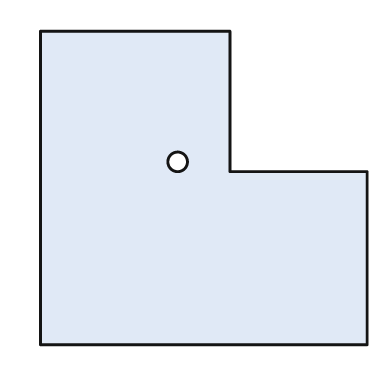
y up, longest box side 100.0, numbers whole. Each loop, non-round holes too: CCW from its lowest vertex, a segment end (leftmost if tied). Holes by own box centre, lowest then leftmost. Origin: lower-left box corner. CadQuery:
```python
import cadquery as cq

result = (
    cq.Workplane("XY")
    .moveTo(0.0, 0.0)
    .lineTo(100.0, 0.0)
    .lineTo(100.0, 53.0)
    .lineTo(58.0, 53.0)
    .lineTo(58.0, 96.0)
    .lineTo(0.0, 96.0)
    .close()
    .moveTo(42.0, 56.0)
    .circle(3.0)
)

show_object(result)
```